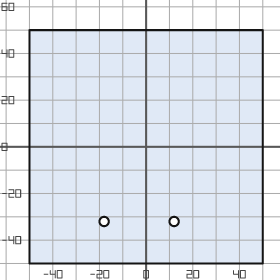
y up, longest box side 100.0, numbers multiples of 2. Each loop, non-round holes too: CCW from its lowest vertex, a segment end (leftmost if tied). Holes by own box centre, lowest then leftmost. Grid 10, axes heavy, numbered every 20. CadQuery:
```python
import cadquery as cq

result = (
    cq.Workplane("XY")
    .moveTo(-50.0, -50.0)
    .lineTo(50.0, -50.0)
    .lineTo(50.0, 50.0)
    .lineTo(-50.0, 50.0)
    .close()
    .moveTo(-18.0, -32.0)
    .circle(2.0)
    .moveTo(12.0, -32.0)
    .circle(2.0)
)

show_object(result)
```